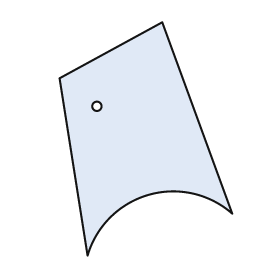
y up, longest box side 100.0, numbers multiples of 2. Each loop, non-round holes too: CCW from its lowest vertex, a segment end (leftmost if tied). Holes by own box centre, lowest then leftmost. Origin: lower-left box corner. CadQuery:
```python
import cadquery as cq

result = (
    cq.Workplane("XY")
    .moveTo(12.0, 0.0)
    .threePointArc((38.0, 26.0), (74.0, 18.0))
    .lineTo(44.0, 100.0)
    .lineTo(0.0, 76.0)
    .close()
    .moveTo(16.0, 64.0)
    .circle(2.0)
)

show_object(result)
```